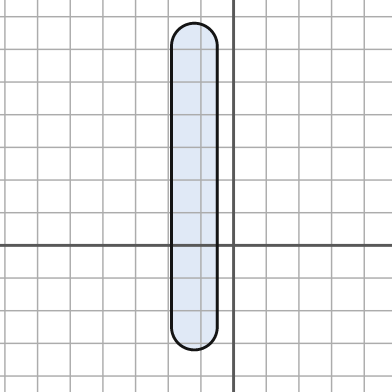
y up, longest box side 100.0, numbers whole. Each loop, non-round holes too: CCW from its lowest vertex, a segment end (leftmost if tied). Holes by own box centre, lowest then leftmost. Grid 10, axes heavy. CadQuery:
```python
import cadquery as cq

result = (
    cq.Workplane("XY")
    .moveTo(-19.0, -25.0)
    .threePointArc((-12.0, -32.0), (-5.0, -25.0))
    .lineTo(-5.0, 61.0)
    .threePointArc((-12.0, 68.0), (-19.0, 61.0))
    .close()
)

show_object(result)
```